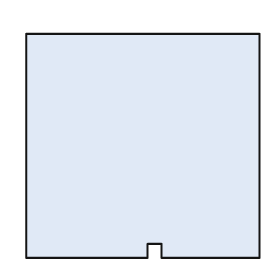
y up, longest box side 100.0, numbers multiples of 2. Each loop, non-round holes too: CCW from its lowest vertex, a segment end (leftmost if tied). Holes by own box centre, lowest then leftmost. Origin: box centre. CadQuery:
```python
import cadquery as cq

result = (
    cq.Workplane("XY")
    .moveTo(-50.0, -48.0)
    .lineTo(2.0, -48.0)
    .lineTo(2.0, -42.0)
    .lineTo(8.0, -42.0)
    .lineTo(8.0, -48.0)
    .lineTo(50.0, -48.0)
    .lineTo(50.0, 48.0)
    .lineTo(-50.0, 48.0)
    .close()
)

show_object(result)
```